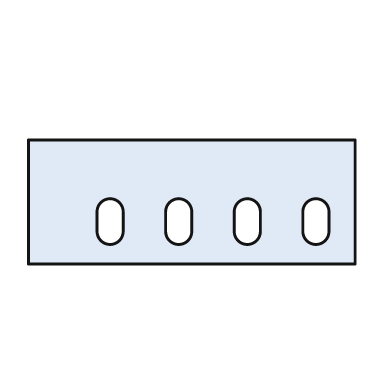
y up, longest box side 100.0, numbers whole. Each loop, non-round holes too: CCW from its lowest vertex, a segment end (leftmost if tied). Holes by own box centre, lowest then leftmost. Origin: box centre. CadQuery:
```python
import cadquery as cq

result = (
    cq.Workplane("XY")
    .moveTo(-50.0, -19.0)
    .lineTo(50.0, -19.0)
    .lineTo(50.0, 19.0)
    .lineTo(-50.0, 19.0)
    .close()
    .moveTo(-29.0, -9.0)
    .threePointArc((-25.0, -13.0), (-21.0, -9.0))
    .lineTo(-21.0, -3.0)
    .threePointArc((-25.0, 1.0), (-29.0, -3.0))
    .close()
    .moveTo(-8.0, -9.0)
    .threePointArc((-4.0, -13.0), (0.0, -9.0))
    .lineTo(0.0, -3.0)
    .threePointArc((-4.0, 1.0), (-8.0, -3.0))
    .close()
    .moveTo(13.0, -9.0)
    .threePointArc((17.0, -13.0), (21.0, -9.0))
    .lineTo(21.0, -3.0)
    .threePointArc((17.0, 1.0), (13.0, -3.0))
    .close()
    .moveTo(34.0, -9.0)
    .threePointArc((38.0, -13.0), (42.0, -9.0))
    .lineTo(42.0, -3.0)
    .threePointArc((38.0, 1.0), (34.0, -3.0))
    .close()
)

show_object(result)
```